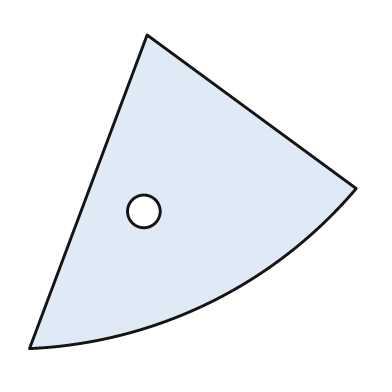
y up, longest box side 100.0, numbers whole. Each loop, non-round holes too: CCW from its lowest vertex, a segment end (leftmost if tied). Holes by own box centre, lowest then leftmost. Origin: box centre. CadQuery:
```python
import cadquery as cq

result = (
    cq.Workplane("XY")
    .moveTo(-50.0, -48.0)
    .threePointArc((5.0, -34.0), (50.0, 1.0))
    .lineTo(-14.0, 48.0)
    .close()
    .moveTo(-15.0, -6.0)
    .circle(5.0)
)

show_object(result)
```